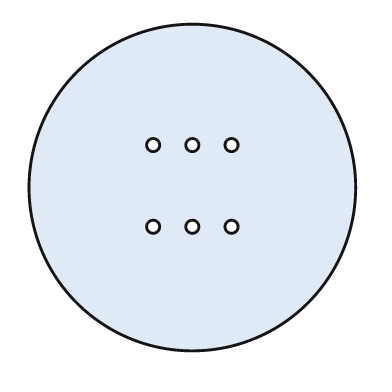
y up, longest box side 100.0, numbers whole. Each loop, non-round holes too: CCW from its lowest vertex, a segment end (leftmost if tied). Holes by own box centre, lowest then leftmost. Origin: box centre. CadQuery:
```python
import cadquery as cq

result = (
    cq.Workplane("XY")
    .moveTo(0.0, 0.0)
    .circle(50.0)
    .moveTo(-12.0, -12.0)
    .circle(2.0)
    .moveTo(0.0, -12.0)
    .circle(2.0)
    .moveTo(12.0, -12.0)
    .circle(2.0)
    .moveTo(-12.0, 13.0)
    .circle(2.0)
    .moveTo(0.0, 13.0)
    .circle(2.0)
    .moveTo(12.0, 13.0)
    .circle(2.0)
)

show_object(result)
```